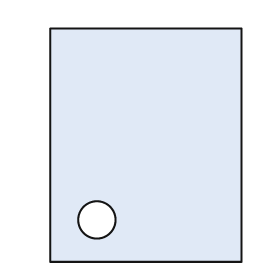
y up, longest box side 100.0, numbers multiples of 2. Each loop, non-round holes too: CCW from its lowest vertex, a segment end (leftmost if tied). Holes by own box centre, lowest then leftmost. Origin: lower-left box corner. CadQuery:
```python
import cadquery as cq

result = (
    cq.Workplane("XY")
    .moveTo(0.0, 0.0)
    .lineTo(82.0, 0.0)
    .lineTo(82.0, 100.0)
    .lineTo(0.0, 100.0)
    .close()
    .moveTo(20.0, 18.0)
    .circle(8.0)
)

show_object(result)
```